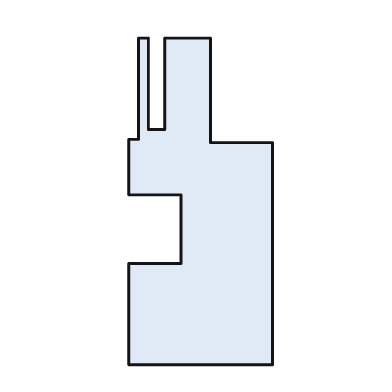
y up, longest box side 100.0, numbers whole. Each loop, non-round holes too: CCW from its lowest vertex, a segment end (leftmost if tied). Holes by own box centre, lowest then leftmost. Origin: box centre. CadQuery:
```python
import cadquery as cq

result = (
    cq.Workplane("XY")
    .moveTo(-22.0, -50.0)
    .lineTo(22.0, -50.0)
    .lineTo(22.0, 18.0)
    .lineTo(3.0, 18.0)
    .lineTo(3.0, 50.0)
    .lineTo(-11.0, 50.0)
    .lineTo(-11.0, 22.0)
    .lineTo(-16.0, 22.0)
    .lineTo(-16.0, 50.0)
    .lineTo(-19.0, 50.0)
    .lineTo(-19.0, 19.0)
    .lineTo(-22.0, 19.0)
    .lineTo(-22.0, 2.0)
    .lineTo(-6.0, 2.0)
    .lineTo(-6.0, -19.0)
    .lineTo(-22.0, -19.0)
    .close()
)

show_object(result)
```